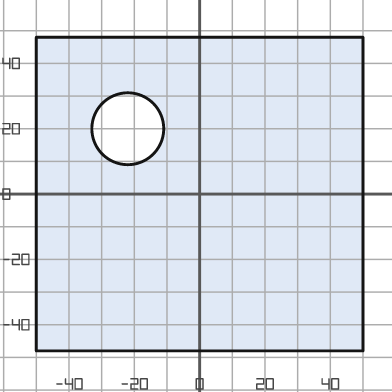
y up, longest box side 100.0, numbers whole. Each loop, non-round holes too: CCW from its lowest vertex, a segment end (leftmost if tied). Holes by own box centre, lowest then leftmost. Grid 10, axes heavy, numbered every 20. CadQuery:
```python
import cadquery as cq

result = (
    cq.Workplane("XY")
    .moveTo(-50.0, -48.0)
    .lineTo(50.0, -48.0)
    .lineTo(50.0, 48.0)
    .lineTo(-50.0, 48.0)
    .close()
    .moveTo(-22.0, 20.0)
    .circle(11.0)
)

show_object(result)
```